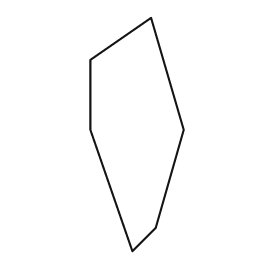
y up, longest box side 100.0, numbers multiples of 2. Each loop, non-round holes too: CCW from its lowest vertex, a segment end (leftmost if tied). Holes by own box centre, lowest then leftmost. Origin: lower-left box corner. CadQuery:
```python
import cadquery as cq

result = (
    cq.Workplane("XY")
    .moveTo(18.0, 0.0)
    .lineTo(28.0, 10.0)
    .lineTo(40.0, 52.0)
    .lineTo(26.0, 100.0)
    .lineTo(0.0, 82.0)
    .lineTo(0.0, 52.0)
    .close()
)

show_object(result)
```